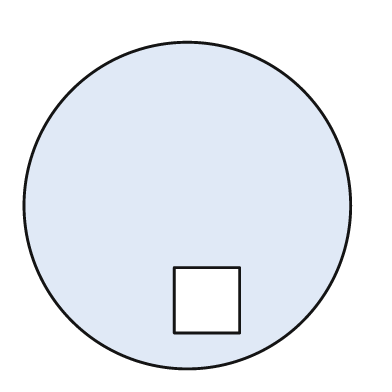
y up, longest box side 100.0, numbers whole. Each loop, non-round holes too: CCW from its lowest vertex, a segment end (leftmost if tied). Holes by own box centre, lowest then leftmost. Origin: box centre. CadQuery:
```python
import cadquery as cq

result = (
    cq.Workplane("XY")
    .moveTo(0.0, 0.0)
    .circle(50.0)
    .moveTo(-4.0, -39.0)
    .lineTo(16.0, -39.0)
    .lineTo(16.0, -19.0)
    .lineTo(-4.0, -19.0)
    .close()
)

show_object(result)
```